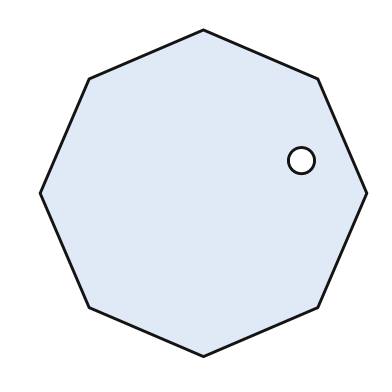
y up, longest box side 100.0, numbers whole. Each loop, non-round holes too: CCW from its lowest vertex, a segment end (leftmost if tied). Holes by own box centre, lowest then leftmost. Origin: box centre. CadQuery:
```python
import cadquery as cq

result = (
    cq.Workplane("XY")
    .moveTo(0.0, -50.0)
    .lineTo(35.0, -35.0)
    .lineTo(50.0, 0.0)
    .lineTo(35.0, 35.0)
    .lineTo(0.0, 50.0)
    .lineTo(-35.0, 35.0)
    .lineTo(-50.0, 0.0)
    .lineTo(-35.0, -35.0)
    .close()
    .moveTo(30.0, 10.0)
    .circle(4.0)
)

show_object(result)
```